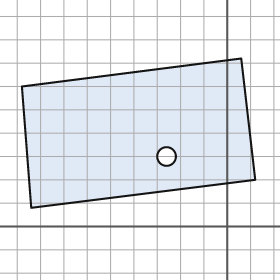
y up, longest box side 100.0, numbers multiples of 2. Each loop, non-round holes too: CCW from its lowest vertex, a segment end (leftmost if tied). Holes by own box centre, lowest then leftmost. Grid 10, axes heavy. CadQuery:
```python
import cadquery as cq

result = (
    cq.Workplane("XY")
    .moveTo(-84.0, 8.0)
    .lineTo(12.0, 20.0)
    .lineTo(6.0, 72.0)
    .lineTo(-88.0, 60.0)
    .close()
    .moveTo(-26.0, 30.0)
    .circle(4.0)
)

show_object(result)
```